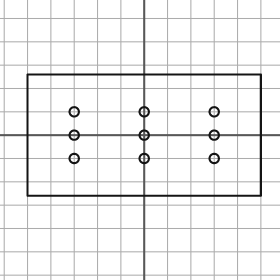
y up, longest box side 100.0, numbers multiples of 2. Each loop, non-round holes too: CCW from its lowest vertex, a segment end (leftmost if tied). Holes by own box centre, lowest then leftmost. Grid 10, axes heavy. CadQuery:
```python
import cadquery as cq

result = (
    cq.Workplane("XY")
    .moveTo(-50.0, -26.0)
    .lineTo(50.0, -26.0)
    .lineTo(50.0, 26.0)
    .lineTo(-50.0, 26.0)
    .close()
    .moveTo(-30.0, -10.0)
    .circle(2.0)
    .moveTo(0.0, -10.0)
    .circle(2.0)
    .moveTo(30.0, -10.0)
    .circle(2.0)
    .moveTo(-30.0, 0.0)
    .circle(2.0)
    .moveTo(0.0, 0.0)
    .circle(2.0)
    .moveTo(30.0, 0.0)
    .circle(2.0)
    .moveTo(-30.0, 10.0)
    .circle(2.0)
    .moveTo(0.0, 10.0)
    .circle(2.0)
    .moveTo(30.0, 10.0)
    .circle(2.0)
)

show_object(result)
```